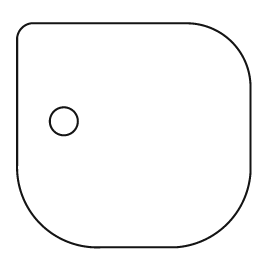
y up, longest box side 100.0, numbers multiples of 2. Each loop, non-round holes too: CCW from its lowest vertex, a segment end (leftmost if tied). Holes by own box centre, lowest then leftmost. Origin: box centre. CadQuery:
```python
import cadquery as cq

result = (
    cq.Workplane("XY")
    .moveTo(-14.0, -48.0)
    .lineTo(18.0, -48.0)
    .threePointArc((40.0, -38.0), (50.0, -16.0))
    .lineTo(50.0, 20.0)
    .threePointArc((42.0, 40.0), (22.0, 48.0))
    .lineTo(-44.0, 48.0)
    .threePointArc((-48.0, 46.0), (-50.0, 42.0))
    .lineTo(-50.0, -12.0)
    .threePointArc((-40.0, -38.0), (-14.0, -48.0))
    .close()
    .moveTo(-30.0, 6.0)
    .circle(6.0)
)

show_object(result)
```